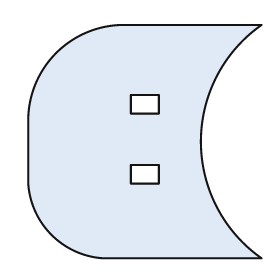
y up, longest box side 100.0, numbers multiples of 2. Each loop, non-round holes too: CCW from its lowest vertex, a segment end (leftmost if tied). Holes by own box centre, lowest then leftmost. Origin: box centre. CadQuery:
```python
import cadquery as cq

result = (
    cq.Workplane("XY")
    .moveTo(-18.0, -50.0)
    .lineTo(50.0, -50.0)
    .threePointArc((24.0, 0.0), (50.0, 50.0))
    .lineTo(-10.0, 50.0)
    .threePointArc((-38.0, 38.0), (-50.0, 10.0))
    .lineTo(-50.0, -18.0)
    .threePointArc((-40.0, -40.0), (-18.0, -50.0))
    .close()
    .moveTo(-6.0, -18.0)
    .lineTo(6.0, -18.0)
    .lineTo(6.0, -10.0)
    .lineTo(-6.0, -10.0)
    .close()
    .moveTo(-6.0, 12.0)
    .lineTo(6.0, 12.0)
    .lineTo(6.0, 20.0)
    .lineTo(-6.0, 20.0)
    .close()
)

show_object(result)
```